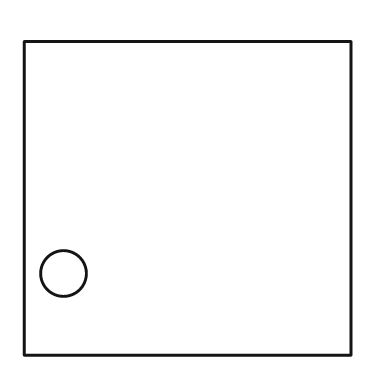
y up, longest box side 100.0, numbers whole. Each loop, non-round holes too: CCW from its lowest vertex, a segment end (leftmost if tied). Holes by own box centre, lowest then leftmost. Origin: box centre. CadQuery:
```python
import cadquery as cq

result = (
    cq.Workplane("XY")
    .moveTo(-50.0, -48.0)
    .lineTo(50.0, -48.0)
    .lineTo(50.0, 48.0)
    .lineTo(-50.0, 48.0)
    .close()
    .moveTo(-38.0, -23.0)
    .circle(7.0)
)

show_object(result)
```